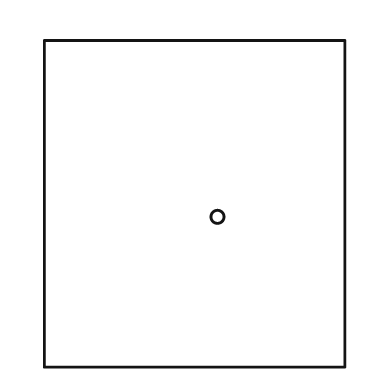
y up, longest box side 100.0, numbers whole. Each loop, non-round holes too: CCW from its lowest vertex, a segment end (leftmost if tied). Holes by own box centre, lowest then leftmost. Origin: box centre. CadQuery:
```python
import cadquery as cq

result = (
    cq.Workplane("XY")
    .moveTo(-46.0, -50.0)
    .lineTo(46.0, -50.0)
    .lineTo(46.0, 50.0)
    .lineTo(-46.0, 50.0)
    .close()
    .moveTo(7.0, -4.0)
    .circle(2.0)
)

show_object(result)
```